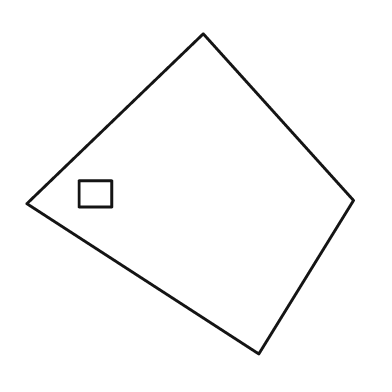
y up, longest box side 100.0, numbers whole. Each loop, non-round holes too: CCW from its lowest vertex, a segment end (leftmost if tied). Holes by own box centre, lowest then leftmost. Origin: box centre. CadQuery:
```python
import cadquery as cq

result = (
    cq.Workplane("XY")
    .moveTo(21.0, -49.0)
    .lineTo(50.0, -2.0)
    .lineTo(4.0, 49.0)
    .lineTo(-50.0, -3.0)
    .close()
    .moveTo(-34.0, -4.0)
    .lineTo(-24.0, -4.0)
    .lineTo(-24.0, 4.0)
    .lineTo(-34.0, 4.0)
    .close()
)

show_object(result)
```